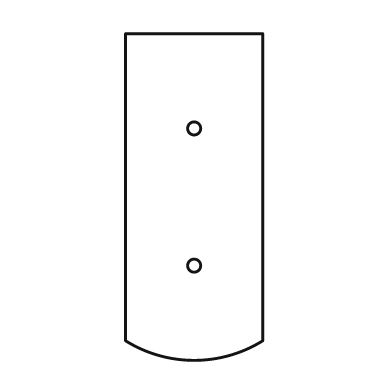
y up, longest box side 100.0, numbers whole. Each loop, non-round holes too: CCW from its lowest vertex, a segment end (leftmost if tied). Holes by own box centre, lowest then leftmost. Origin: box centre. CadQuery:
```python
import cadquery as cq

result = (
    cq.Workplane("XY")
    .moveTo(-21.0, -44.0)
    .threePointArc((0.0, -50.0), (21.0, -44.0))
    .lineTo(21.0, 50.0)
    .lineTo(-21.0, 50.0)
    .close()
    .moveTo(0.0, -21.0)
    .circle(2.0)
    .moveTo(0.0, 21.0)
    .circle(2.0)
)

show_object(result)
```